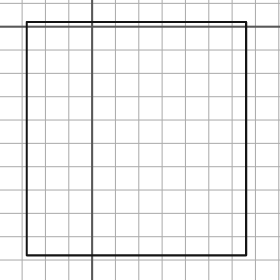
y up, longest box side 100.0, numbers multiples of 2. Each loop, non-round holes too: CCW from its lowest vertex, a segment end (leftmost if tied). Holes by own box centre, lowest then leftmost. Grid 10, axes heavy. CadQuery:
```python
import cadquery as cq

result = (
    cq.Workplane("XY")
    .moveTo(-28.0, -98.0)
    .lineTo(66.0, -98.0)
    .lineTo(66.0, 2.0)
    .lineTo(-28.0, 2.0)
    .close()
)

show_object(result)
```